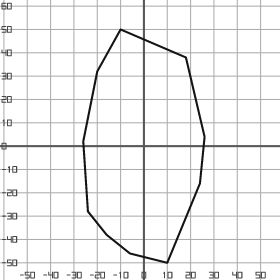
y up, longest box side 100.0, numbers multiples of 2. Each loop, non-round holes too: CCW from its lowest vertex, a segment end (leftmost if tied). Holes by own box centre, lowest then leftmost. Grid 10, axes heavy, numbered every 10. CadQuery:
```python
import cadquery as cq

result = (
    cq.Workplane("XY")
    .moveTo(10.0, -50.0)
    .lineTo(24.0, -16.0)
    .lineTo(26.0, 4.0)
    .lineTo(18.0, 38.0)
    .lineTo(-10.0, 50.0)
    .lineTo(-20.0, 32.0)
    .lineTo(-26.0, 2.0)
    .lineTo(-24.0, -28.0)
    .lineTo(-16.0, -38.0)
    .lineTo(-6.0, -46.0)
    .close()
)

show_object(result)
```